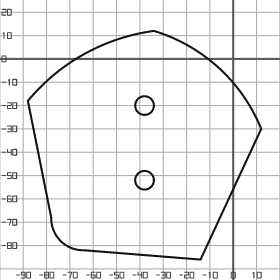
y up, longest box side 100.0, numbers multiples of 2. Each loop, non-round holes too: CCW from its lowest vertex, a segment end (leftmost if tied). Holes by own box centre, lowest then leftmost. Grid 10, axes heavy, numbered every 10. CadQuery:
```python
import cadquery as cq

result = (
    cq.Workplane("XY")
    .moveTo(-14.0, -86.0)
    .lineTo(12.0, -30.0)
    .threePointArc((-6.0, -4.0), (-34.0, 12.0))
    .threePointArc((-64.0, 2.0), (-88.0, -18.0))
    .lineTo(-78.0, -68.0)
    .threePointArc((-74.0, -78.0), (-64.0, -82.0))
    .close()
    .moveTo(-38.0, -52.0)
    .circle(4.0)
    .moveTo(-38.0, -20.0)
    .circle(4.0)
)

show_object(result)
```